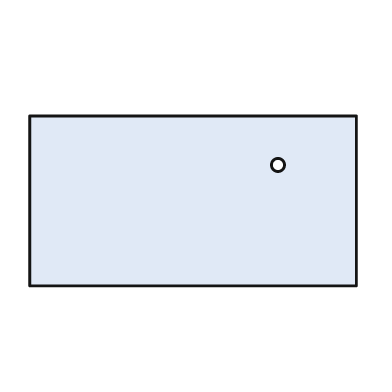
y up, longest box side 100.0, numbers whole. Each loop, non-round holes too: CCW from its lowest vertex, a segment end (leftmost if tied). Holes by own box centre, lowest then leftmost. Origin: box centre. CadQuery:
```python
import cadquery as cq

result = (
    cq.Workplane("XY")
    .moveTo(-50.0, -26.0)
    .lineTo(50.0, -26.0)
    .lineTo(50.0, 26.0)
    .lineTo(-50.0, 26.0)
    .close()
    .moveTo(26.0, 11.0)
    .circle(2.0)
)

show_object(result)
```